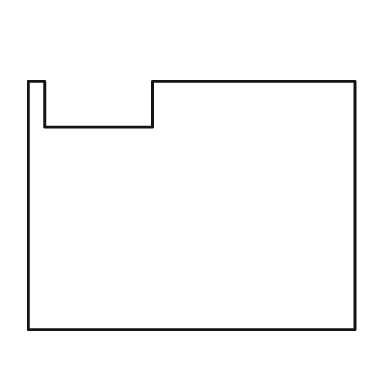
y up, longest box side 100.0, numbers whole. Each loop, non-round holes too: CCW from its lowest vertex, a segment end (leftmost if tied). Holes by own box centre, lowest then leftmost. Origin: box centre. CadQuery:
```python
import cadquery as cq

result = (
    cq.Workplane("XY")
    .moveTo(-50.0, -38.0)
    .lineTo(50.0, -38.0)
    .lineTo(50.0, 38.0)
    .lineTo(-12.0, 38.0)
    .lineTo(-12.0, 24.0)
    .lineTo(-45.0, 24.0)
    .lineTo(-45.0, 38.0)
    .lineTo(-50.0, 38.0)
    .close()
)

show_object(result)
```